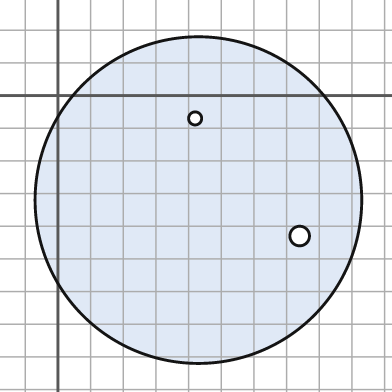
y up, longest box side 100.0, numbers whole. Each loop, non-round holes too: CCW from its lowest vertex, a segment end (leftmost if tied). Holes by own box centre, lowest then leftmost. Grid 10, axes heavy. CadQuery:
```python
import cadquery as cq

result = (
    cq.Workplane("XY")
    .moveTo(43.0, -32.0)
    .circle(50.0)
    .moveTo(74.0, -43.0)
    .circle(3.0)
    .moveTo(42.0, -7.0)
    .circle(2.0)
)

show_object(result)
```